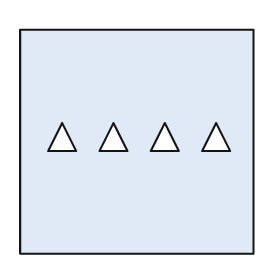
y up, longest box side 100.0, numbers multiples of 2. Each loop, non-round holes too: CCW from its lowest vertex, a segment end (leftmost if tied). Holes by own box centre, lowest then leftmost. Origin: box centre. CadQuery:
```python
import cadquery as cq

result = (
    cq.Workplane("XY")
    .moveTo(-50.0, -48.0)
    .lineTo(50.0, -48.0)
    .lineTo(50.0, 48.0)
    .lineTo(-50.0, 48.0)
    .close()
    .moveTo(-38.0, -4.0)
    .lineTo(-26.0, -4.0)
    .lineTo(-32.0, 8.0)
    .close()
    .moveTo(-16.0, -4.0)
    .lineTo(-4.0, -4.0)
    .lineTo(-10.0, 8.0)
    .close()
    .moveTo(6.0, -4.0)
    .lineTo(18.0, -4.0)
    .lineTo(12.0, 8.0)
    .close()
    .moveTo(28.0, -4.0)
    .lineTo(40.0, -4.0)
    .lineTo(34.0, 8.0)
    .close()
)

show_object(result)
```